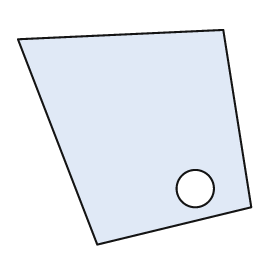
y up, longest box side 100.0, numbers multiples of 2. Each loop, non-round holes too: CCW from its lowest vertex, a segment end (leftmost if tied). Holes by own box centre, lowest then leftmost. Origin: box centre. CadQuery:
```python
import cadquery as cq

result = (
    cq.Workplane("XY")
    .moveTo(-16.0, -46.0)
    .lineTo(50.0, -30.0)
    .lineTo(38.0, 46.0)
    .lineTo(-50.0, 42.0)
    .close()
    .moveTo(26.0, -22.0)
    .circle(8.0)
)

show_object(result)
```